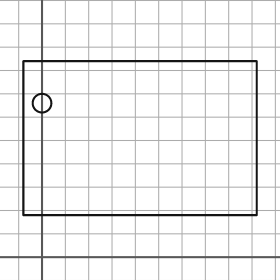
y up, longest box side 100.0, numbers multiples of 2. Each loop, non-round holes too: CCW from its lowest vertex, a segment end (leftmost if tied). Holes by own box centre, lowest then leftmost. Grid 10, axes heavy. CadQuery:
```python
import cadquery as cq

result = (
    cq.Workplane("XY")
    .moveTo(-8.0, 18.0)
    .lineTo(92.0, 18.0)
    .lineTo(92.0, 84.0)
    .lineTo(-8.0, 84.0)
    .close()
    .moveTo(0.0, 66.0)
    .circle(4.0)
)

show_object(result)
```